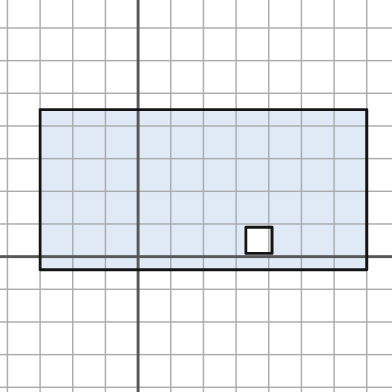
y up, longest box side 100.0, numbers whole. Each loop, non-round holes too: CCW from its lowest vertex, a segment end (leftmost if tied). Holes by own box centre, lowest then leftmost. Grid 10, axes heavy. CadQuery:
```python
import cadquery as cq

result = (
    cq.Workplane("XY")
    .moveTo(-30.0, -4.0)
    .lineTo(70.0, -4.0)
    .lineTo(70.0, 45.0)
    .lineTo(-30.0, 45.0)
    .close()
    .moveTo(33.0, 1.0)
    .lineTo(41.0, 1.0)
    .lineTo(41.0, 9.0)
    .lineTo(33.0, 9.0)
    .close()
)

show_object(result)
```